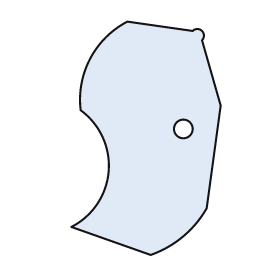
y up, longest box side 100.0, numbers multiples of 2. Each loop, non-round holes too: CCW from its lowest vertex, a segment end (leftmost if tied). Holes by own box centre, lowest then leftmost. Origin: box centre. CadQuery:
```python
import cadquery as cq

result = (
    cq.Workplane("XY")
    .moveTo(2.0, -50.0)
    .threePointArc((16.0, -42.0), (26.0, -30.0))
    .lineTo(32.0, 14.0)
    .lineTo(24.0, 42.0)
    .threePointArc((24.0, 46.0), (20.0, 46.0))
    .lineTo(-8.0, 50.0)
    .threePointArc((-24.0, 34.0), (-28.0, 12.0))
    .threePointArc((-16.0, -14.0), (-32.0, -38.0))
    .close()
    .moveTo(16.0, 4.0)
    .circle(4.0)
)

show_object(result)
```